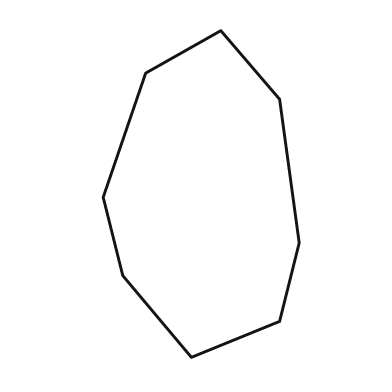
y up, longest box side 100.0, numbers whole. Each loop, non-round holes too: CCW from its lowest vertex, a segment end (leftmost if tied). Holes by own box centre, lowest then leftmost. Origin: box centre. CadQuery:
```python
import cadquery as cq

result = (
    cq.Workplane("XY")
    .moveTo(-3.0, -50.0)
    .lineTo(24.0, -39.0)
    .lineTo(30.0, -15.0)
    .lineTo(24.0, 29.0)
    .lineTo(6.0, 50.0)
    .lineTo(-17.0, 37.0)
    .lineTo(-30.0, -1.0)
    .lineTo(-24.0, -25.0)
    .close()
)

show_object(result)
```